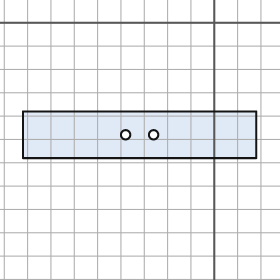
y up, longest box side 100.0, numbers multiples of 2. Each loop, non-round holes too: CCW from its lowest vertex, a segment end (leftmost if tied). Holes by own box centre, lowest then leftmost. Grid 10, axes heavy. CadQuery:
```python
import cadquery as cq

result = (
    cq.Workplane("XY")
    .moveTo(-82.0, -58.0)
    .lineTo(18.0, -58.0)
    .lineTo(18.0, -38.0)
    .lineTo(-82.0, -38.0)
    .close()
    .moveTo(-38.0, -48.0)
    .circle(2.0)
    .moveTo(-26.0, -48.0)
    .circle(2.0)
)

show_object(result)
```